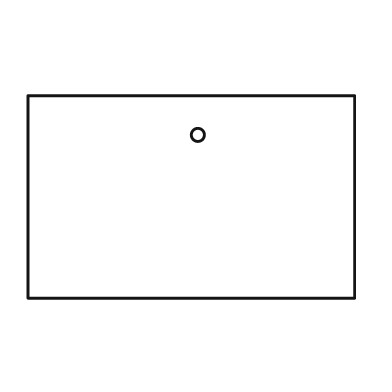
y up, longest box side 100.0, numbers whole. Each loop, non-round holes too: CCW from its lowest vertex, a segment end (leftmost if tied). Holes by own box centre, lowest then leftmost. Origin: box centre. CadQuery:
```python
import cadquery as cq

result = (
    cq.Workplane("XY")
    .moveTo(-50.0, -31.0)
    .lineTo(50.0, -31.0)
    .lineTo(50.0, 31.0)
    .lineTo(-50.0, 31.0)
    .close()
    .moveTo(2.0, 19.0)
    .circle(2.0)
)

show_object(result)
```